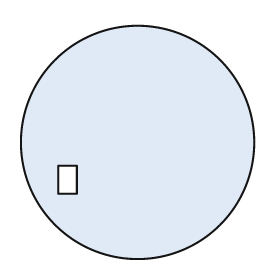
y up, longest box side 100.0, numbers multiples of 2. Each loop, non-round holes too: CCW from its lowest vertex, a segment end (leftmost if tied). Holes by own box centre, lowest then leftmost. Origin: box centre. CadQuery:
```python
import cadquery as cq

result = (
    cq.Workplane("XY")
    .moveTo(0.0, 0.0)
    .circle(50.0)
    .moveTo(-34.0, -22.0)
    .lineTo(-26.0, -22.0)
    .lineTo(-26.0, -10.0)
    .lineTo(-34.0, -10.0)
    .close()
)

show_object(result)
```